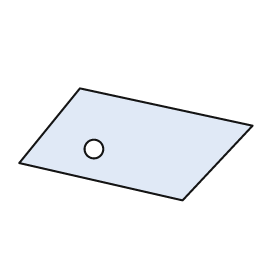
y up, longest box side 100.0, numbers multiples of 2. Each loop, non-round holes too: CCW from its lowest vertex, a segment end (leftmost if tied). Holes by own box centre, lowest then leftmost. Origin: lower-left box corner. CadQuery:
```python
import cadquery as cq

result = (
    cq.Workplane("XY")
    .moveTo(70.0, 0.0)
    .lineTo(100.0, 32.0)
    .lineTo(26.0, 48.0)
    .lineTo(0.0, 16.0)
    .close()
    .moveTo(32.0, 22.0)
    .circle(4.0)
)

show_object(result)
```